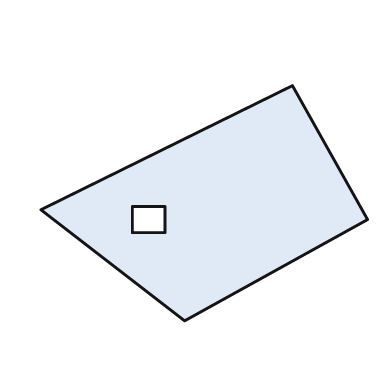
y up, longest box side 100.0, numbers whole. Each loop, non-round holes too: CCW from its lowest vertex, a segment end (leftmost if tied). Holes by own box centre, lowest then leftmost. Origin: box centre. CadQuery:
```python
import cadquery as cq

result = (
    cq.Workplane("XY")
    .moveTo(-6.0, -36.0)
    .lineTo(50.0, -5.0)
    .lineTo(27.0, 36.0)
    .lineTo(-50.0, -2.0)
    .close()
    .moveTo(-22.0, -9.0)
    .lineTo(-12.0, -9.0)
    .lineTo(-12.0, -1.0)
    .lineTo(-22.0, -1.0)
    .close()
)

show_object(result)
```